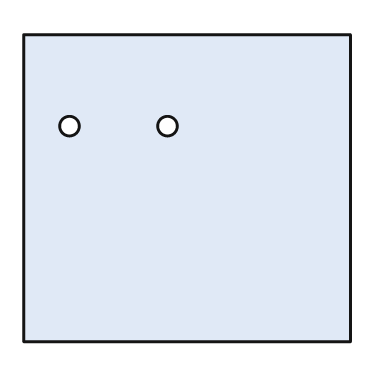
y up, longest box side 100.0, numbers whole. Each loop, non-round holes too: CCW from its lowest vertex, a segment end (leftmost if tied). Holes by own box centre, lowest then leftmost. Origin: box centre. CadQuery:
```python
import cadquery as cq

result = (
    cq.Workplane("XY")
    .moveTo(-50.0, -47.0)
    .lineTo(50.0, -47.0)
    .lineTo(50.0, 47.0)
    .lineTo(-50.0, 47.0)
    .close()
    .moveTo(-36.0, 19.0)
    .circle(3.0)
    .moveTo(-6.0, 19.0)
    .circle(3.0)
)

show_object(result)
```